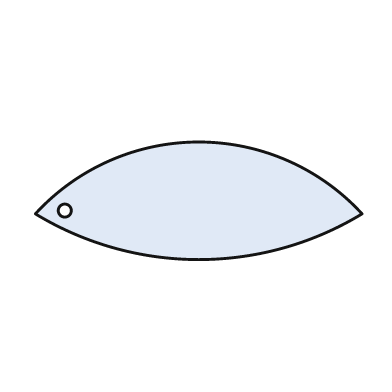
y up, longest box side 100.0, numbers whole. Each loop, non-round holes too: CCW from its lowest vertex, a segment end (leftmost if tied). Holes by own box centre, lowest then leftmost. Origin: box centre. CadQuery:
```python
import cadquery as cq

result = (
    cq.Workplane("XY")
    .moveTo(-50.0, -4.0)
    .threePointArc((0.0, -18.0), (50.0, -4.0))
    .threePointArc((0.0, 18.0), (-50.0, -4.0))
    .close()
    .moveTo(-41.0, -3.0)
    .circle(2.0)
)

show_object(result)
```